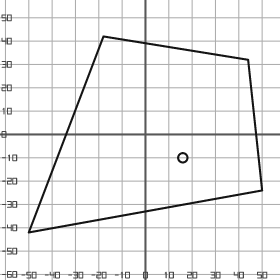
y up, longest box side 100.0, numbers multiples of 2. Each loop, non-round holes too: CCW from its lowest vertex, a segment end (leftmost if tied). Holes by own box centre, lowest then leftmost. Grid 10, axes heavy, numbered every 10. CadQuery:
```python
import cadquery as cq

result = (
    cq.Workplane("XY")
    .moveTo(-50.0, -42.0)
    .lineTo(50.0, -24.0)
    .lineTo(44.0, 32.0)
    .lineTo(-18.0, 42.0)
    .close()
    .moveTo(16.0, -10.0)
    .circle(2.0)
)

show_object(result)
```